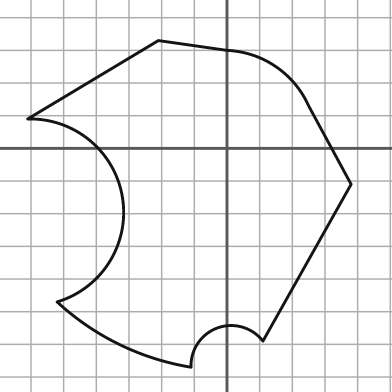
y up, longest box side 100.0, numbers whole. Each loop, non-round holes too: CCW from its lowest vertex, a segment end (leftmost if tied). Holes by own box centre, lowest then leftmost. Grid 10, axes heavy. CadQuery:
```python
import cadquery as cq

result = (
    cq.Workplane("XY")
    .moveTo(-11.0, -67.0)
    .threePointArc((-3.0, -55.0), (11.0, -59.0))
    .lineTo(38.0, -11.0)
    .lineTo(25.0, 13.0)
    .threePointArc((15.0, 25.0), (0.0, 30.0))
    .lineTo(-21.0, 33.0)
    .lineTo(-61.0, 9.0)
    .threePointArc((-32.0, -15.0), (-52.0, -47.0))
    .threePointArc((-33.0, -60.0), (-11.0, -67.0))
    .close()
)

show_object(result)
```